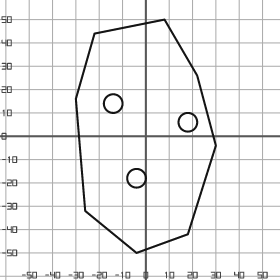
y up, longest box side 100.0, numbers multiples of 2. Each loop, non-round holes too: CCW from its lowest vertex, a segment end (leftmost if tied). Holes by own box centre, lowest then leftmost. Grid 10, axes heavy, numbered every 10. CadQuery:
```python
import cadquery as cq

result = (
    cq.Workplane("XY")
    .moveTo(-4.0, -50.0)
    .lineTo(18.0, -42.0)
    .lineTo(30.0, -4.0)
    .lineTo(22.0, 26.0)
    .lineTo(8.0, 50.0)
    .lineTo(-22.0, 44.0)
    .lineTo(-30.0, 16.0)
    .lineTo(-26.0, -32.0)
    .close()
    .moveTo(-4.0, -18.0)
    .circle(4.0)
    .moveTo(18.0, 6.0)
    .circle(4.0)
    .moveTo(-14.0, 14.0)
    .circle(4.0)
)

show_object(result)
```